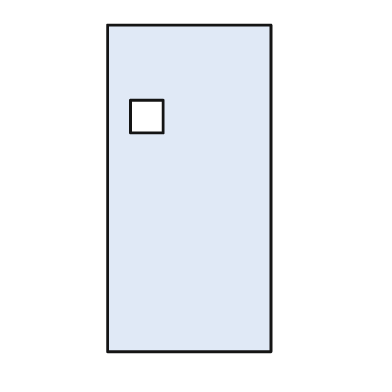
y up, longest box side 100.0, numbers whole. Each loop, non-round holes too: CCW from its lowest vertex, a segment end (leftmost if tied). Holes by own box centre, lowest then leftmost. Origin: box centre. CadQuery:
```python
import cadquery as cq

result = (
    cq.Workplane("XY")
    .moveTo(-25.0, -50.0)
    .lineTo(25.0, -50.0)
    .lineTo(25.0, 50.0)
    .lineTo(-25.0, 50.0)
    .close()
    .moveTo(-18.0, 17.0)
    .lineTo(-8.0, 17.0)
    .lineTo(-8.0, 27.0)
    .lineTo(-18.0, 27.0)
    .close()
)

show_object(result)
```